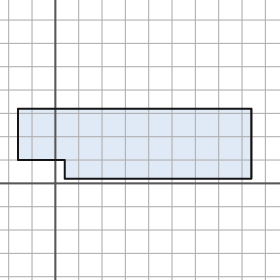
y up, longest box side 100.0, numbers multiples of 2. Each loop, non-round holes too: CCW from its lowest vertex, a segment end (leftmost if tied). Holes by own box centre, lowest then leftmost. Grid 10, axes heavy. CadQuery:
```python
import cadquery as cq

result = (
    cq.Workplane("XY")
    .moveTo(4.0, 2.0)
    .lineTo(84.0, 2.0)
    .lineTo(84.0, 32.0)
    .lineTo(-16.0, 32.0)
    .lineTo(-16.0, 10.0)
    .lineTo(4.0, 10.0)
    .close()
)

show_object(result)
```